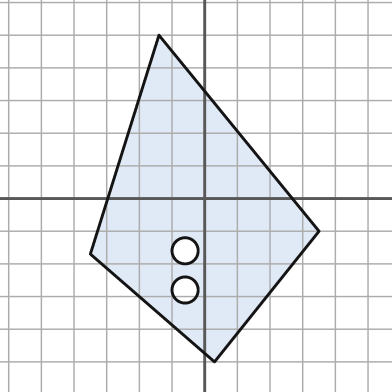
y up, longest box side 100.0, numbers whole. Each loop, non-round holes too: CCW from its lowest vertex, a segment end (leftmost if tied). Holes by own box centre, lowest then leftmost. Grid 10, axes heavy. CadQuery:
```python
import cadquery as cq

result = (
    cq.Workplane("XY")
    .moveTo(3.0, -50.0)
    .lineTo(35.0, -10.0)
    .lineTo(-14.0, 50.0)
    .lineTo(-35.0, -17.0)
    .close()
    .moveTo(-6.0, -28.0)
    .circle(4.0)
    .moveTo(-6.0, -16.0)
    .circle(4.0)
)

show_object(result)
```